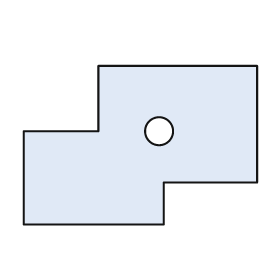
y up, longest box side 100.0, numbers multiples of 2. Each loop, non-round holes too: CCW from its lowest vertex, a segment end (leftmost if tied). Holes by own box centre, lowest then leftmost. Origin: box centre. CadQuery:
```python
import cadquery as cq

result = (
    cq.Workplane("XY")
    .moveTo(-50.0, -34.0)
    .lineTo(10.0, -34.0)
    .lineTo(10.0, -16.0)
    .lineTo(50.0, -16.0)
    .lineTo(50.0, 34.0)
    .lineTo(-18.0, 34.0)
    .lineTo(-18.0, 6.0)
    .lineTo(-50.0, 6.0)
    .close()
    .moveTo(8.0, 6.0)
    .circle(6.0)
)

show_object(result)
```